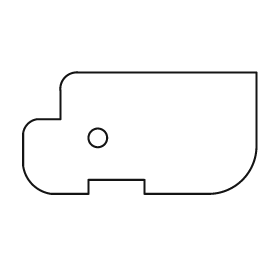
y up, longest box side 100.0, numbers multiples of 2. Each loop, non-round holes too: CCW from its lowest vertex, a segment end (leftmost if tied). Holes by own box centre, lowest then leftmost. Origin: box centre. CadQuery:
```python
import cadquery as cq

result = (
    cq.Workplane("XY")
    .moveTo(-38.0, -26.0)
    .lineTo(-22.0, -26.0)
    .lineTo(-22.0, -20.0)
    .lineTo(2.0, -20.0)
    .lineTo(2.0, -26.0)
    .lineTo(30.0, -26.0)
    .threePointArc((44.0, -20.0), (50.0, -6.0))
    .lineTo(50.0, 26.0)
    .lineTo(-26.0, 26.0)
    .threePointArc((-32.0, 24.0), (-34.0, 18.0))
    .lineTo(-34.0, 6.0)
    .lineTo(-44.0, 6.0)
    .threePointArc((-48.0, 4.0), (-50.0, 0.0))
    .lineTo(-50.0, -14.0)
    .threePointArc((-46.0, -22.0), (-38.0, -26.0))
    .close()
    .moveTo(-18.0, -2.0)
    .circle(4.0)
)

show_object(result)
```